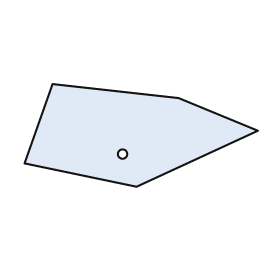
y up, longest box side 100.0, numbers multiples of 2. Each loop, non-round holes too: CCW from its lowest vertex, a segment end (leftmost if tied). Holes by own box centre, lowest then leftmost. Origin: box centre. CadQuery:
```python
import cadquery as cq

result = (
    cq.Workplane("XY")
    .moveTo(-2.0, -22.0)
    .lineTo(50.0, 2.0)
    .lineTo(16.0, 16.0)
    .lineTo(-38.0, 22.0)
    .lineTo(-50.0, -12.0)
    .close()
    .moveTo(-8.0, -8.0)
    .circle(2.0)
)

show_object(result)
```